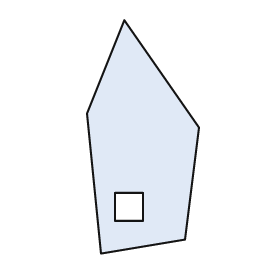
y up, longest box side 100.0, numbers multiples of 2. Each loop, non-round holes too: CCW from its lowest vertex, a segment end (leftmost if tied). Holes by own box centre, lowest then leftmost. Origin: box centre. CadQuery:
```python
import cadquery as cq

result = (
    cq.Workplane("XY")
    .moveTo(-18.0, -50.0)
    .lineTo(18.0, -44.0)
    .lineTo(24.0, 4.0)
    .lineTo(-8.0, 50.0)
    .lineTo(-24.0, 10.0)
    .close()
    .moveTo(-12.0, -36.0)
    .lineTo(0.0, -36.0)
    .lineTo(0.0, -24.0)
    .lineTo(-12.0, -24.0)
    .close()
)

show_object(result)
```